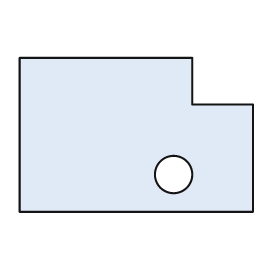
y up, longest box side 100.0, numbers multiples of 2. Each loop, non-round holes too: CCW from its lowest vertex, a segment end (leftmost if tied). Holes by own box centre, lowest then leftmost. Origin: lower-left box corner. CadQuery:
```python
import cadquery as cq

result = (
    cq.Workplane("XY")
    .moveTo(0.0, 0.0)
    .lineTo(100.0, 0.0)
    .lineTo(100.0, 46.0)
    .lineTo(74.0, 46.0)
    .lineTo(74.0, 66.0)
    .lineTo(0.0, 66.0)
    .close()
    .moveTo(66.0, 16.0)
    .circle(8.0)
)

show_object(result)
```